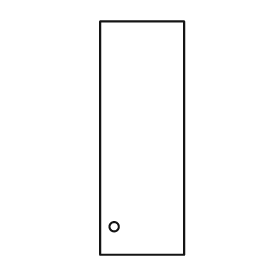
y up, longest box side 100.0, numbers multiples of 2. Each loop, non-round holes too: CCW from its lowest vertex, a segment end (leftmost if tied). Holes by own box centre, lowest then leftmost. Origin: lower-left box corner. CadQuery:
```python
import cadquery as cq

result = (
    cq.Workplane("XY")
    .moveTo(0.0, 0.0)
    .lineTo(36.0, 0.0)
    .lineTo(36.0, 100.0)
    .lineTo(0.0, 100.0)
    .close()
    .moveTo(6.0, 12.0)
    .circle(2.0)
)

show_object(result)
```